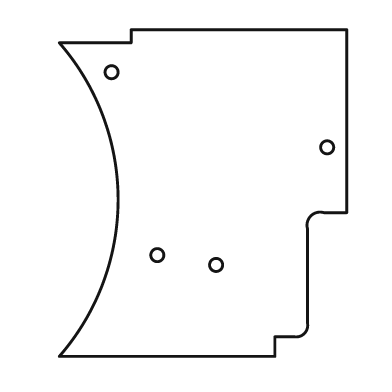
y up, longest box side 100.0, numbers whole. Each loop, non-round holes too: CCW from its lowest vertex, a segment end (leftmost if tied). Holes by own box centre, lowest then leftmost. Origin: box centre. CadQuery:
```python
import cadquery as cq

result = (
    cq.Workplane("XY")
    .moveTo(-44.0, -50.0)
    .lineTo(22.0, -50.0)
    .lineTo(22.0, -44.0)
    .lineTo(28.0, -44.0)
    .threePointArc((31.0, -43.0), (32.0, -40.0))
    .lineTo(32.0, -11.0)
    .threePointArc((33.0, -7.0), (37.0, -6.0))
    .lineTo(44.0, -6.0)
    .lineTo(44.0, 50.0)
    .lineTo(-22.0, 50.0)
    .lineTo(-22.0, 46.0)
    .lineTo(-44.0, 46.0)
    .threePointArc((-26.0, -2.0), (-44.0, -50.0))
    .close()
    .moveTo(4.0, -22.0)
    .circle(2.0)
    .moveTo(-14.0, -19.0)
    .circle(2.0)
    .moveTo(38.0, 14.0)
    .circle(2.0)
    .moveTo(-28.0, 37.0)
    .circle(2.0)
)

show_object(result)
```